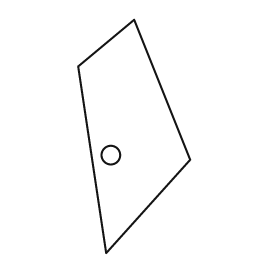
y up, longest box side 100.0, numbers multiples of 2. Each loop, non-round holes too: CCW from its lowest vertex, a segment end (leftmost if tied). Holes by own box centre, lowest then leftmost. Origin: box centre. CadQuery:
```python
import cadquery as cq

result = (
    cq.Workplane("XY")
    .moveTo(-12.0, -50.0)
    .lineTo(24.0, -10.0)
    .lineTo(0.0, 50.0)
    .lineTo(-24.0, 30.0)
    .close()
    .moveTo(-10.0, -8.0)
    .circle(4.0)
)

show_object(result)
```